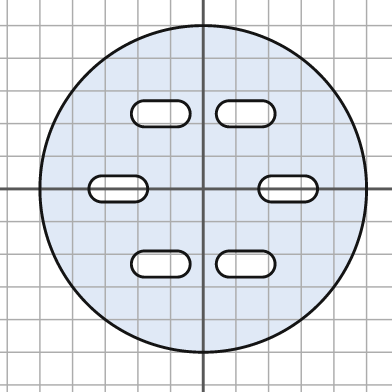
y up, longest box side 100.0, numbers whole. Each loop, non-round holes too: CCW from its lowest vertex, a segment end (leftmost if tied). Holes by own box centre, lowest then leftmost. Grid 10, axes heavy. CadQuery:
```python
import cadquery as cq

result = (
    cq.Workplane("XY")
    .moveTo(0.0, 0.0)
    .circle(50.0)
    .moveTo(-18.0, -27.0)
    .lineTo(-8.0, -27.0)
    .threePointArc((-4.0, -23.0), (-8.0, -19.0))
    .lineTo(-18.0, -19.0)
    .threePointArc((-22.0, -23.0), (-18.0, -27.0))
    .close()
    .moveTo(8.0, -27.0)
    .lineTo(18.0, -27.0)
    .threePointArc((22.0, -23.0), (18.0, -19.0))
    .lineTo(8.0, -19.0)
    .threePointArc((4.0, -23.0), (8.0, -27.0))
    .close()
    .moveTo(-31.0, -4.0)
    .lineTo(-21.0, -4.0)
    .threePointArc((-17.0, 0.0), (-21.0, 4.0))
    .lineTo(-31.0, 4.0)
    .threePointArc((-35.0, 0.0), (-31.0, -4.0))
    .close()
    .moveTo(21.0, -4.0)
    .lineTo(31.0, -4.0)
    .threePointArc((35.0, 0.0), (31.0, 4.0))
    .lineTo(21.0, 4.0)
    .threePointArc((17.0, 0.0), (21.0, -4.0))
    .close()
    .moveTo(-18.0, 19.0)
    .lineTo(-8.0, 19.0)
    .threePointArc((-4.0, 23.0), (-8.0, 27.0))
    .lineTo(-18.0, 27.0)
    .threePointArc((-22.0, 23.0), (-18.0, 19.0))
    .close()
    .moveTo(8.0, 19.0)
    .lineTo(18.0, 19.0)
    .threePointArc((22.0, 23.0), (18.0, 27.0))
    .lineTo(8.0, 27.0)
    .threePointArc((4.0, 23.0), (8.0, 19.0))
    .close()
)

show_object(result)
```